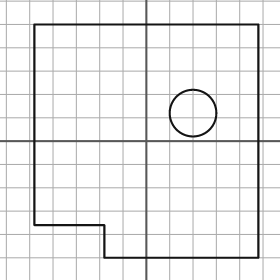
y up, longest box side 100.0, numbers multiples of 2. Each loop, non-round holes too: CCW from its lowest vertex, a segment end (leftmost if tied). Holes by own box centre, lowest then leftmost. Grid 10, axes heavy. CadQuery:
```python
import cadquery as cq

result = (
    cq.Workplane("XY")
    .moveTo(-18.0, -50.0)
    .lineTo(48.0, -50.0)
    .lineTo(48.0, 50.0)
    .lineTo(-48.0, 50.0)
    .lineTo(-48.0, -36.0)
    .lineTo(-18.0, -36.0)
    .close()
    .moveTo(20.0, 12.0)
    .circle(10.0)
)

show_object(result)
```